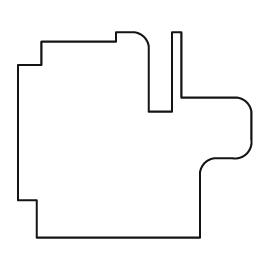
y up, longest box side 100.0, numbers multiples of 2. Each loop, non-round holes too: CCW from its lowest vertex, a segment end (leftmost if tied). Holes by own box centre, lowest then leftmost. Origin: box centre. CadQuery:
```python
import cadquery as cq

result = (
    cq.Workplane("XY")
    .moveTo(-42.0, -44.0)
    .lineTo(28.0, -44.0)
    .lineTo(28.0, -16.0)
    .threePointArc((30.0, -12.0), (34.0, -10.0))
    .lineTo(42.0, -10.0)
    .threePointArc((48.0, -8.0), (50.0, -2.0))
    .lineTo(50.0, 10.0)
    .threePointArc((48.0, 14.0), (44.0, 16.0))
    .lineTo(20.0, 16.0)
    .lineTo(20.0, 44.0)
    .lineTo(16.0, 44.0)
    .lineTo(16.0, 10.0)
    .lineTo(6.0, 10.0)
    .lineTo(6.0, 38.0)
    .threePointArc((4.0, 42.0), (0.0, 44.0))
    .lineTo(-8.0, 44.0)
    .lineTo(-8.0, 40.0)
    .lineTo(-40.0, 40.0)
    .lineTo(-40.0, 30.0)
    .lineTo(-50.0, 30.0)
    .lineTo(-50.0, -28.0)
    .lineTo(-42.0, -28.0)
    .close()
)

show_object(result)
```